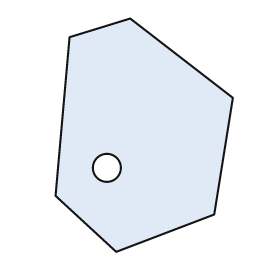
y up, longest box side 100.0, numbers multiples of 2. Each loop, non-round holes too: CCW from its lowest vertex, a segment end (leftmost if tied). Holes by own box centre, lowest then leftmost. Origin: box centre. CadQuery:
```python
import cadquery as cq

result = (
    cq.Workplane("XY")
    .moveTo(-12.0, -50.0)
    .lineTo(30.0, -34.0)
    .lineTo(38.0, 16.0)
    .lineTo(-6.0, 50.0)
    .lineTo(-32.0, 42.0)
    .lineTo(-38.0, -26.0)
    .close()
    .moveTo(-16.0, -14.0)
    .circle(6.0)
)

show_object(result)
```